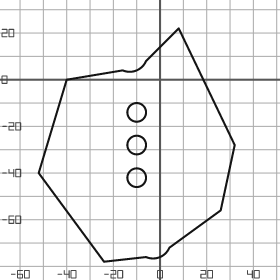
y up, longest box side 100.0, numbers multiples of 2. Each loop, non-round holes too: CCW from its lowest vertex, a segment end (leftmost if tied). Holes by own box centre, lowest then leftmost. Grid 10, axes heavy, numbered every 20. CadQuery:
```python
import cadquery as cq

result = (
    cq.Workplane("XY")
    .moveTo(-24.0, -78.0)
    .lineTo(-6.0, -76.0)
    .threePointArc((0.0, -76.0), (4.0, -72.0))
    .lineTo(26.0, -56.0)
    .lineTo(32.0, -28.0)
    .lineTo(8.0, 22.0)
    .lineTo(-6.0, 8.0)
    .threePointArc((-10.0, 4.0), (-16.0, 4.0))
    .lineTo(-40.0, 0.0)
    .lineTo(-52.0, -40.0)
    .close()
    .moveTo(-10.0, -42.0)
    .circle(4.0)
    .moveTo(-10.0, -28.0)
    .circle(4.0)
    .moveTo(-10.0, -14.0)
    .circle(4.0)
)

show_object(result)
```